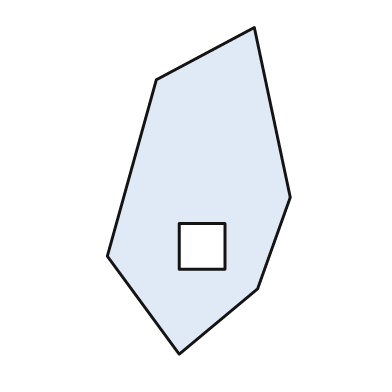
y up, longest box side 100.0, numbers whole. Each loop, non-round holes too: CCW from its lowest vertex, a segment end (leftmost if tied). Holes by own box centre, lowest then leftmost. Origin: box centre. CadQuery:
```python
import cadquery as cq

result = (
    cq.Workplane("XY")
    .moveTo(-6.0, -50.0)
    .lineTo(18.0, -30.0)
    .lineTo(28.0, -2.0)
    .lineTo(17.0, 50.0)
    .lineTo(-13.0, 34.0)
    .lineTo(-28.0, -20.0)
    .close()
    .moveTo(-6.0, -24.0)
    .lineTo(8.0, -24.0)
    .lineTo(8.0, -10.0)
    .lineTo(-6.0, -10.0)
    .close()
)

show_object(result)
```